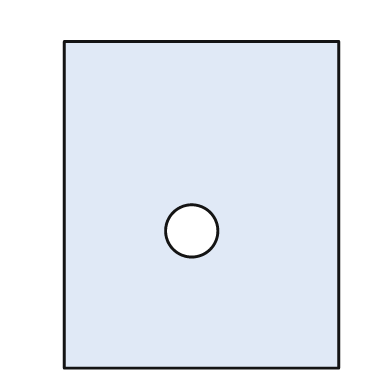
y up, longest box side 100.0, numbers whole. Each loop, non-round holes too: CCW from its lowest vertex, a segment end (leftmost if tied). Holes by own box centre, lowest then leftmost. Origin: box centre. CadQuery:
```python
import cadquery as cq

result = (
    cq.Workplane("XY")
    .moveTo(-42.0, -50.0)
    .lineTo(42.0, -50.0)
    .lineTo(42.0, 50.0)
    .lineTo(-42.0, 50.0)
    .close()
    .moveTo(-3.0, -8.0)
    .circle(8.0)
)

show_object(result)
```